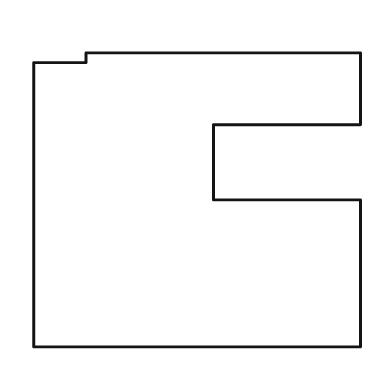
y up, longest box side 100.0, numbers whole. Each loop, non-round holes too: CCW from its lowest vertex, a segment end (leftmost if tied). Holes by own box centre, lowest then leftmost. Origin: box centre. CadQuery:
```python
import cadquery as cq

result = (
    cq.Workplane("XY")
    .moveTo(-50.0, -45.0)
    .lineTo(50.0, -45.0)
    .lineTo(50.0, 0.0)
    .lineTo(5.0, 0.0)
    .lineTo(5.0, 23.0)
    .lineTo(50.0, 23.0)
    .lineTo(50.0, 45.0)
    .lineTo(-34.0, 45.0)
    .lineTo(-34.0, 42.0)
    .lineTo(-50.0, 42.0)
    .close()
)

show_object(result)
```